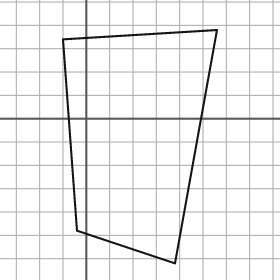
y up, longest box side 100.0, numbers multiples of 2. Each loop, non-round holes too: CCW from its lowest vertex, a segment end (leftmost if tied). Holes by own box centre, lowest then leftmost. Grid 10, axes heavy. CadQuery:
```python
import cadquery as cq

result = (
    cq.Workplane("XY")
    .moveTo(38.0, -62.0)
    .lineTo(56.0, 38.0)
    .lineTo(-10.0, 34.0)
    .lineTo(-4.0, -48.0)
    .close()
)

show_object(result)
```